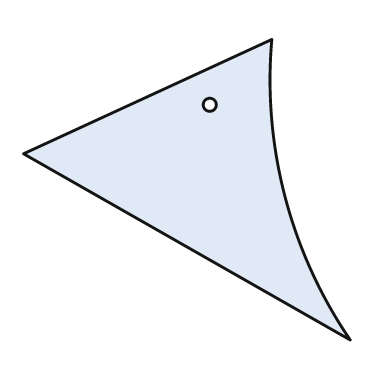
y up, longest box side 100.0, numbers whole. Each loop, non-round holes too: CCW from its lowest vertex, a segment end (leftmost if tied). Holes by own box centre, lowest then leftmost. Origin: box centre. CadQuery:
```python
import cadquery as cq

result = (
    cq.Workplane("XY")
    .moveTo(50.0, -46.0)
    .threePointArc((30.0, -2.0), (26.0, 46.0))
    .lineTo(-50.0, 11.0)
    .close()
    .moveTo(7.0, 26.0)
    .circle(2.0)
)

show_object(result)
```